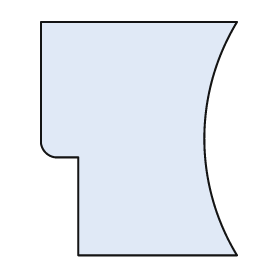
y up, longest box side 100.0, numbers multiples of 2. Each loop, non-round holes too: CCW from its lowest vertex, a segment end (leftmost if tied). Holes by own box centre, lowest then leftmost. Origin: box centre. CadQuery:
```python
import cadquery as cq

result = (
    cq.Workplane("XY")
    .moveTo(-26.0, -50.0)
    .lineTo(42.0, -50.0)
    .threePointArc((28.0, 0.0), (42.0, 50.0))
    .lineTo(-42.0, 50.0)
    .lineTo(-42.0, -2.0)
    .threePointArc((-40.0, -6.0), (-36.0, -8.0))
    .lineTo(-26.0, -8.0)
    .close()
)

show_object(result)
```